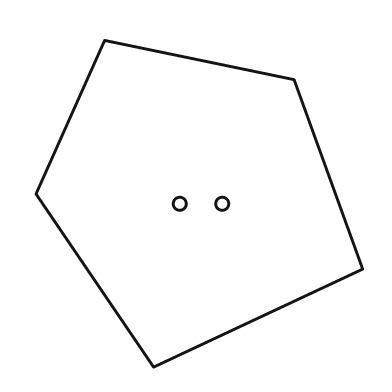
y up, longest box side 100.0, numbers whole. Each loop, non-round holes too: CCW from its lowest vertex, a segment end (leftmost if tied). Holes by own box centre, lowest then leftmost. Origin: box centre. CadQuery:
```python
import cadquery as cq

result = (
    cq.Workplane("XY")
    .moveTo(-14.0, -50.0)
    .lineTo(50.0, -20.0)
    .lineTo(29.0, 38.0)
    .lineTo(-29.0, 50.0)
    .lineTo(-50.0, 3.0)
    .close()
    .moveTo(-6.0, 0.0)
    .circle(2.0)
    .moveTo(7.0, 0.0)
    .circle(2.0)
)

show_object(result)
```